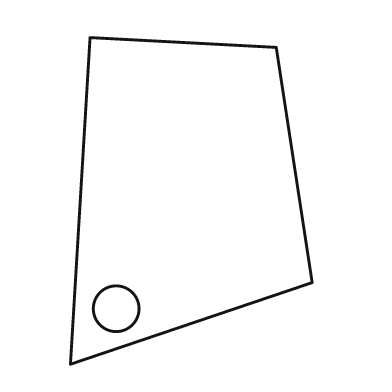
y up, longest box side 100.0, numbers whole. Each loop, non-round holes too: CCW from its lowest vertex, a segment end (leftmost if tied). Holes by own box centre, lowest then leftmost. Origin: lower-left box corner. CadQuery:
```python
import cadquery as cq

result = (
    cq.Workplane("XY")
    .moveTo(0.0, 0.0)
    .lineTo(74.0, 25.0)
    .lineTo(63.0, 97.0)
    .lineTo(6.0, 100.0)
    .close()
    .moveTo(14.0, 17.0)
    .circle(7.0)
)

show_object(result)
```